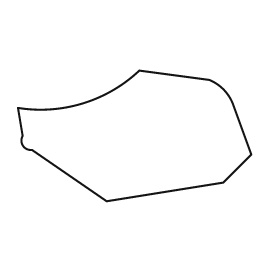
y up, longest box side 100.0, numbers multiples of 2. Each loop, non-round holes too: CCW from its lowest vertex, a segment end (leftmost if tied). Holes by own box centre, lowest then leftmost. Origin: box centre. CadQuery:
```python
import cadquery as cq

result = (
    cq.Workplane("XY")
    .moveTo(-12.0, -28.0)
    .lineTo(38.0, -20.0)
    .lineTo(50.0, -8.0)
    .lineTo(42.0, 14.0)
    .threePointArc((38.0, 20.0), (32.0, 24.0))
    .lineTo(2.0, 28.0)
    .threePointArc((-22.0, 14.0), (-50.0, 12.0))
    .lineTo(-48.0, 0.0)
    .threePointArc((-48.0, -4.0), (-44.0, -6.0))
    .close()
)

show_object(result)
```